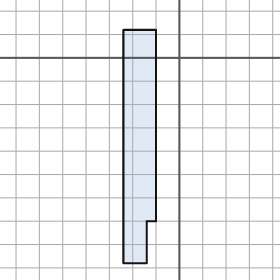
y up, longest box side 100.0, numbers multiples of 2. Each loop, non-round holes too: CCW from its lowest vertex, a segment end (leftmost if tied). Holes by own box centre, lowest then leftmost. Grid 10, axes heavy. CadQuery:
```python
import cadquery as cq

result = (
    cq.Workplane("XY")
    .moveTo(-24.0, -88.0)
    .lineTo(-14.0, -88.0)
    .lineTo(-14.0, -70.0)
    .lineTo(-10.0, -70.0)
    .lineTo(-10.0, 12.0)
    .lineTo(-24.0, 12.0)
    .close()
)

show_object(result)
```